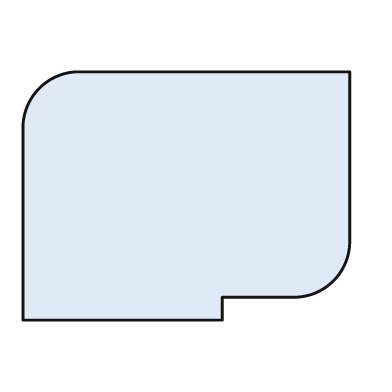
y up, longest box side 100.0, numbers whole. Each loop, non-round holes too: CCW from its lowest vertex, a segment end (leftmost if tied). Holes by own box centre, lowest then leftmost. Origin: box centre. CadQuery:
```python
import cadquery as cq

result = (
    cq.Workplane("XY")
    .moveTo(-50.0, -38.0)
    .lineTo(11.0, -38.0)
    .lineTo(11.0, -31.0)
    .lineTo(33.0, -31.0)
    .threePointArc((45.0, -26.0), (50.0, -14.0))
    .lineTo(50.0, 38.0)
    .lineTo(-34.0, 38.0)
    .threePointArc((-45.0, 33.0), (-50.0, 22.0))
    .close()
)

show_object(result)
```